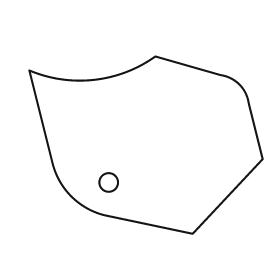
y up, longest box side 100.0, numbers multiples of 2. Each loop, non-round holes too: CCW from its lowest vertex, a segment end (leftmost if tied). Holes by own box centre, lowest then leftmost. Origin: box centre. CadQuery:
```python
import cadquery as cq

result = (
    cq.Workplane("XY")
    .moveTo(20.0, -38.0)
    .lineTo(50.0, -6.0)
    .lineTo(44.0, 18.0)
    .threePointArc((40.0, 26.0), (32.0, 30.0))
    .lineTo(4.0, 38.0)
    .threePointArc((-22.0, 28.0), (-50.0, 32.0))
    .lineTo(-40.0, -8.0)
    .threePointArc((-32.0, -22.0), (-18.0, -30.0))
    .close()
    .moveTo(-16.0, -16.0)
    .circle(4.0)
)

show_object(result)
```